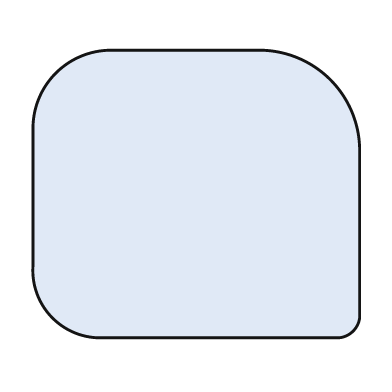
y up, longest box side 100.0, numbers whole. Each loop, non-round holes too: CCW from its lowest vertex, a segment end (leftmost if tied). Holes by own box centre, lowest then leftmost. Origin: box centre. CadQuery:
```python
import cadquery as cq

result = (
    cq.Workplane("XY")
    .moveTo(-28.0, -44.0)
    .lineTo(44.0, -44.0)
    .threePointArc((48.0, -42.0), (50.0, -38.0))
    .lineTo(50.0, 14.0)
    .threePointArc((41.0, 35.0), (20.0, 44.0))
    .lineTo(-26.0, 44.0)
    .threePointArc((-43.0, 37.0), (-50.0, 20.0))
    .lineTo(-50.0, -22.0)
    .threePointArc((-44.0, -38.0), (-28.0, -44.0))
    .close()
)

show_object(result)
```